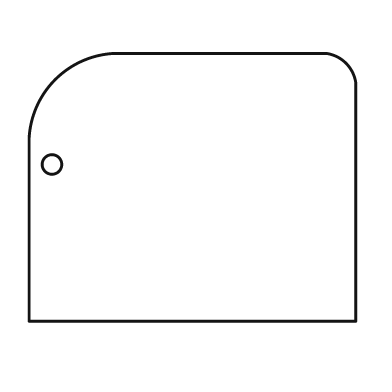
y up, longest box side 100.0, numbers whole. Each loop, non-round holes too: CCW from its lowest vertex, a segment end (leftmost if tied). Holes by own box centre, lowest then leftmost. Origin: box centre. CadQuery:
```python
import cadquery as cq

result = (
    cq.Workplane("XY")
    .moveTo(-50.0, -41.0)
    .lineTo(50.0, -41.0)
    .lineTo(50.0, 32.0)
    .threePointArc((47.0, 38.0), (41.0, 41.0))
    .lineTo(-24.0, 41.0)
    .threePointArc((-42.0, 33.0), (-50.0, 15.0))
    .close()
    .moveTo(-43.0, 7.0)
    .circle(3.0)
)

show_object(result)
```